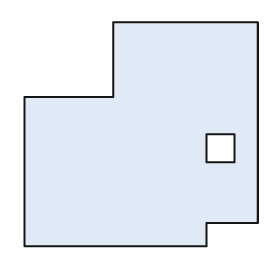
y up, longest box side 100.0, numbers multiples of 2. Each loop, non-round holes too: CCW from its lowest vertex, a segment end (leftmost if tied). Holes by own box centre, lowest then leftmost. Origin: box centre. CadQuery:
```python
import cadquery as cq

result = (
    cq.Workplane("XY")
    .moveTo(-50.0, -48.0)
    .lineTo(28.0, -48.0)
    .lineTo(28.0, -38.0)
    .lineTo(50.0, -38.0)
    .lineTo(50.0, 48.0)
    .lineTo(-12.0, 48.0)
    .lineTo(-12.0, 16.0)
    .lineTo(-50.0, 16.0)
    .close()
    .moveTo(28.0, -12.0)
    .lineTo(40.0, -12.0)
    .lineTo(40.0, 0.0)
    .lineTo(28.0, 0.0)
    .close()
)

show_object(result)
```